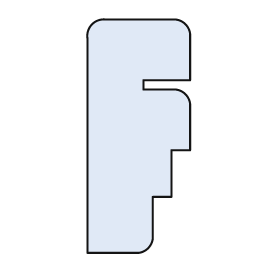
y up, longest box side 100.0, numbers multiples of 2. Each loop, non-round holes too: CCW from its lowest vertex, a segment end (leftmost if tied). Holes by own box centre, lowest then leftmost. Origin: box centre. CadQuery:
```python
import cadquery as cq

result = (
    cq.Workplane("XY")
    .moveTo(-22.0, -50.0)
    .lineTo(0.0, -50.0)
    .threePointArc((4.0, -48.0), (6.0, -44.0))
    .lineTo(6.0, -26.0)
    .lineTo(14.0, -26.0)
    .lineTo(14.0, -6.0)
    .lineTo(22.0, -6.0)
    .lineTo(22.0, 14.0)
    .threePointArc((20.0, 18.0), (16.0, 20.0))
    .lineTo(2.0, 20.0)
    .lineTo(2.0, 24.0)
    .lineTo(22.0, 24.0)
    .lineTo(22.0, 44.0)
    .threePointArc((20.0, 48.0), (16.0, 50.0))
    .lineTo(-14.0, 50.0)
    .threePointArc((-20.0, 48.0), (-22.0, 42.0))
    .close()
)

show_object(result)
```